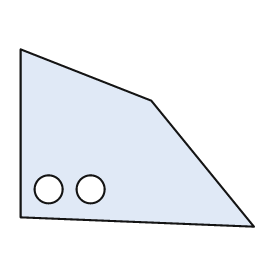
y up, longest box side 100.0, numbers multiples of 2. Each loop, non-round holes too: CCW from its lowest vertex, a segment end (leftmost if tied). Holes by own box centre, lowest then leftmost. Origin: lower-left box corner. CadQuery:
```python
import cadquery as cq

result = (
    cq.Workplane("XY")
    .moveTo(100.0, 0.0)
    .lineTo(56.0, 54.0)
    .lineTo(0.0, 76.0)
    .lineTo(0.0, 4.0)
    .close()
    .moveTo(12.0, 16.0)
    .circle(6.0)
    .moveTo(30.0, 16.0)
    .circle(6.0)
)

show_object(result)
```